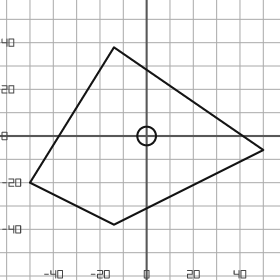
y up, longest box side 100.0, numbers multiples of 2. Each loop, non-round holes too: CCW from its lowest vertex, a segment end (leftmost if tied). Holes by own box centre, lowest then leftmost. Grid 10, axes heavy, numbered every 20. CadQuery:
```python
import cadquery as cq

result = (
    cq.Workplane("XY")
    .moveTo(-14.0, -38.0)
    .lineTo(50.0, -6.0)
    .lineTo(-14.0, 38.0)
    .lineTo(-50.0, -20.0)
    .close()
    .moveTo(0.0, 0.0)
    .circle(4.0)
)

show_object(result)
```